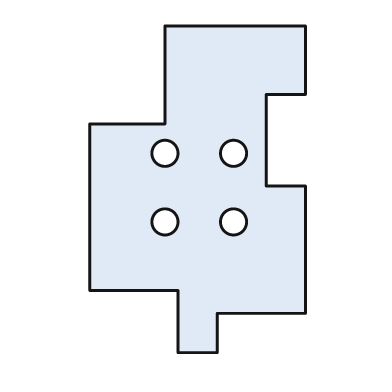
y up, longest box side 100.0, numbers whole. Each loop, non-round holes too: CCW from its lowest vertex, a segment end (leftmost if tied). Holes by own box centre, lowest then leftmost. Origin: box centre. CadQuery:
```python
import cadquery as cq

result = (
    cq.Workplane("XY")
    .moveTo(-6.0, -50.0)
    .lineTo(6.0, -50.0)
    .lineTo(6.0, -38.0)
    .lineTo(33.0, -38.0)
    .lineTo(33.0, 1.0)
    .lineTo(21.0, 1.0)
    .lineTo(21.0, 29.0)
    .lineTo(33.0, 29.0)
    .lineTo(33.0, 50.0)
    .lineTo(-10.0, 50.0)
    .lineTo(-10.0, 20.0)
    .lineTo(-33.0, 20.0)
    .lineTo(-33.0, -31.0)
    .lineTo(-6.0, -31.0)
    .close()
    .moveTo(-10.0, -10.0)
    .circle(4.0)
    .moveTo(11.0, -10.0)
    .circle(4.0)
    .moveTo(-10.0, 11.0)
    .circle(4.0)
    .moveTo(11.0, 11.0)
    .circle(4.0)
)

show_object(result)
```